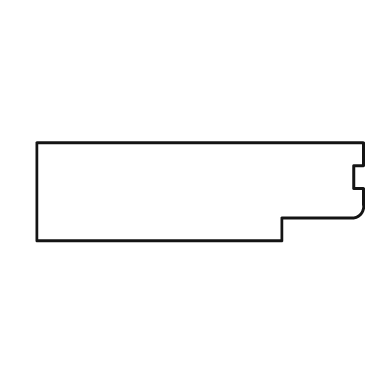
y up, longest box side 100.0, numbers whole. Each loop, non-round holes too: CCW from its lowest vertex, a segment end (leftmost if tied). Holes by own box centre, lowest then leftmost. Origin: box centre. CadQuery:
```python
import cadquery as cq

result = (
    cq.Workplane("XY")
    .moveTo(-50.0, -15.0)
    .lineTo(25.0, -15.0)
    .lineTo(25.0, -8.0)
    .lineTo(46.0, -8.0)
    .threePointArc((49.0, -7.0), (50.0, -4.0))
    .lineTo(50.0, 1.0)
    .lineTo(47.0, 1.0)
    .lineTo(47.0, 8.0)
    .lineTo(50.0, 8.0)
    .lineTo(50.0, 15.0)
    .lineTo(-50.0, 15.0)
    .close()
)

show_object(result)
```